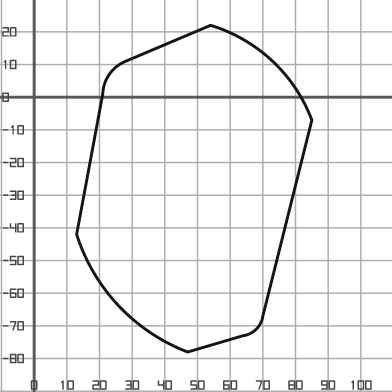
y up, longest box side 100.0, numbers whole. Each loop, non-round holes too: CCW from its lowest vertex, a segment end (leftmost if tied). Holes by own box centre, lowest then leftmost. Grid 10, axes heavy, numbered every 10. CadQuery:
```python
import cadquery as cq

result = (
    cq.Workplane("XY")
    .moveTo(47.0, -78.0)
    .lineTo(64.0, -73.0)
    .threePointArc((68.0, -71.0), (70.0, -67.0))
    .lineTo(85.0, -7.0)
    .threePointArc((73.0, 11.0), (54.0, 22.0))
    .lineTo(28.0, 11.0)
    .threePointArc((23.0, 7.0), (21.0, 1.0))
    .lineTo(13.0, -42.0)
    .threePointArc((26.0, -64.0), (47.0, -78.0))
    .close()
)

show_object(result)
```